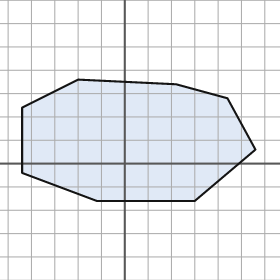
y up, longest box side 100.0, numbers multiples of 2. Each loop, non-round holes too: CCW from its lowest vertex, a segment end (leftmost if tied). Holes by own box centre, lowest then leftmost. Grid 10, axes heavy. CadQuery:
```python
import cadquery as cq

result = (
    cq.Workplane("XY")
    .moveTo(-12.0, -16.0)
    .lineTo(30.0, -16.0)
    .lineTo(56.0, 6.0)
    .lineTo(44.0, 28.0)
    .lineTo(22.0, 34.0)
    .lineTo(-20.0, 36.0)
    .lineTo(-44.0, 24.0)
    .lineTo(-44.0, -4.0)
    .close()
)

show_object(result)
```